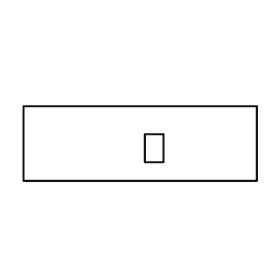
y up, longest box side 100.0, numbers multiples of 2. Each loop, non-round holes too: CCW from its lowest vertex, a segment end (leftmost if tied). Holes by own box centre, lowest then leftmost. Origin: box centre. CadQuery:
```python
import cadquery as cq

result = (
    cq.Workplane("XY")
    .moveTo(-50.0, -16.0)
    .lineTo(50.0, -16.0)
    .lineTo(50.0, 16.0)
    .lineTo(-50.0, 16.0)
    .close()
    .moveTo(2.0, -8.0)
    .lineTo(10.0, -8.0)
    .lineTo(10.0, 4.0)
    .lineTo(2.0, 4.0)
    .close()
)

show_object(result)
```